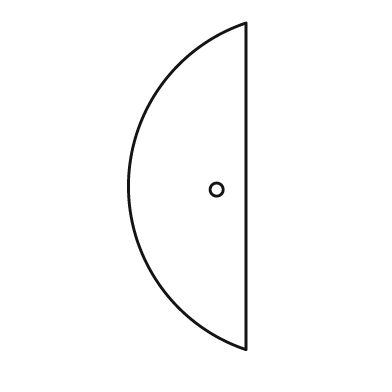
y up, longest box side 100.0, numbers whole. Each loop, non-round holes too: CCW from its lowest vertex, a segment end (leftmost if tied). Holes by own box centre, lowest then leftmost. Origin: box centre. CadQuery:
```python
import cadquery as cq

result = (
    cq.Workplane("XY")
    .moveTo(18.0, -50.0)
    .lineTo(18.0, 50.0)
    .threePointArc((-18.0, 0.0), (18.0, -50.0))
    .close()
    .moveTo(9.0, -1.0)
    .circle(2.0)
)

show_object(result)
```